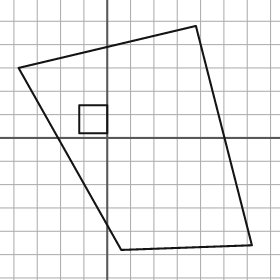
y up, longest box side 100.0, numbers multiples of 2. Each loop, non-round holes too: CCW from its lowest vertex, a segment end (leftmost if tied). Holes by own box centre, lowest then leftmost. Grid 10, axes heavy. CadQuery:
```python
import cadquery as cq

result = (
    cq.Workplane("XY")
    .moveTo(6.0, -48.0)
    .lineTo(62.0, -46.0)
    .lineTo(38.0, 48.0)
    .lineTo(-38.0, 30.0)
    .close()
    .moveTo(-12.0, 2.0)
    .lineTo(0.0, 2.0)
    .lineTo(0.0, 14.0)
    .lineTo(-12.0, 14.0)
    .close()
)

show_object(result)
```